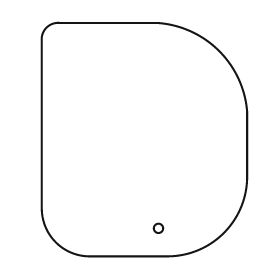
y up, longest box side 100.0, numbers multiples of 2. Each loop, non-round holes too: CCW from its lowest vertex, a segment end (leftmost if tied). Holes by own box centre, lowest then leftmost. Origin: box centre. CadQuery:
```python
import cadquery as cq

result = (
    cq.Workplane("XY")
    .moveTo(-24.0, -50.0)
    .lineTo(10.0, -50.0)
    .threePointArc((34.0, -40.0), (44.0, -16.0))
    .lineTo(44.0, 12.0)
    .threePointArc((32.0, 38.0), (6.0, 50.0))
    .lineTo(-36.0, 50.0)
    .threePointArc((-42.0, 48.0), (-44.0, 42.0))
    .lineTo(-44.0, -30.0)
    .threePointArc((-38.0, -44.0), (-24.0, -50.0))
    .close()
    .moveTo(6.0, -38.0)
    .circle(2.0)
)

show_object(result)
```